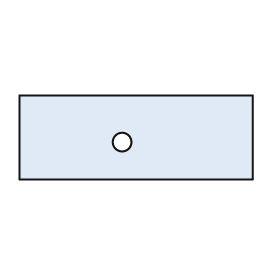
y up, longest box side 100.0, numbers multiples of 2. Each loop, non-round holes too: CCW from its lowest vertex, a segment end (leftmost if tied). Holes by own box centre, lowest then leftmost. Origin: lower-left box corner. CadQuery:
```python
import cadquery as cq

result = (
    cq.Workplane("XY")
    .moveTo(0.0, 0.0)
    .lineTo(100.0, 0.0)
    .lineTo(100.0, 36.0)
    .lineTo(0.0, 36.0)
    .close()
    .moveTo(44.0, 16.0)
    .circle(4.0)
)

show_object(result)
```